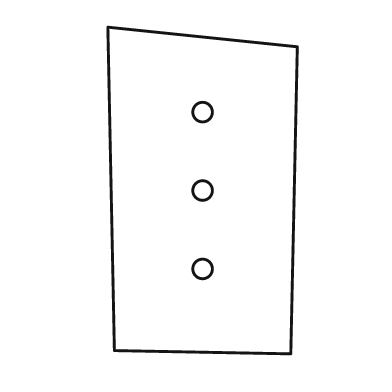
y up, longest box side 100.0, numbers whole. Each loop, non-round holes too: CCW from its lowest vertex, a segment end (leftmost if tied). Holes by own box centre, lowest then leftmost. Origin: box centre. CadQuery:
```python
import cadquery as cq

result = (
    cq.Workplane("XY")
    .moveTo(27.0, -50.0)
    .lineTo(29.0, 44.0)
    .lineTo(-29.0, 50.0)
    .lineTo(-27.0, -49.0)
    .close()
    .moveTo(0.0, -24.0)
    .circle(3.0)
    .moveTo(0.0, 0.0)
    .circle(3.0)
    .moveTo(0.0, 24.0)
    .circle(3.0)
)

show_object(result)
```